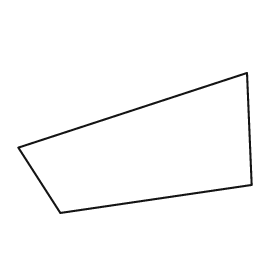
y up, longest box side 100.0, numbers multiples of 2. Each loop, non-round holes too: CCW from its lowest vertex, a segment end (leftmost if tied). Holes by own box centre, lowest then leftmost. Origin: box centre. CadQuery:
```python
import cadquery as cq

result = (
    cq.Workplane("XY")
    .moveTo(-32.0, -30.0)
    .lineTo(50.0, -18.0)
    .lineTo(48.0, 30.0)
    .lineTo(-50.0, -2.0)
    .close()
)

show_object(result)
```